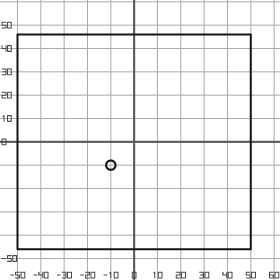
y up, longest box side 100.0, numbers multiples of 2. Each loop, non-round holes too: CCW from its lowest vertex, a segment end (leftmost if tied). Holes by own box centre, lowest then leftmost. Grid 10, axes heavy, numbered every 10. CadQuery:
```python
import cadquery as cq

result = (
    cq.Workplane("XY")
    .moveTo(-50.0, -46.0)
    .lineTo(50.0, -46.0)
    .lineTo(50.0, 46.0)
    .lineTo(-50.0, 46.0)
    .close()
    .moveTo(-10.0, -10.0)
    .circle(2.0)
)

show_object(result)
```